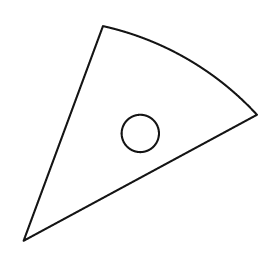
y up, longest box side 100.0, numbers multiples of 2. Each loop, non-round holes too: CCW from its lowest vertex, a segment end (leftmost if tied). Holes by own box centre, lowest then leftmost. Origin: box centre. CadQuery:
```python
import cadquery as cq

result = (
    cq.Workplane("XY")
    .moveTo(-50.0, -46.0)
    .lineTo(50.0, 8.0)
    .threePointArc((20.0, 32.0), (-16.0, 46.0))
    .close()
    .moveTo(0.0, 0.0)
    .circle(8.0)
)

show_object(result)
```